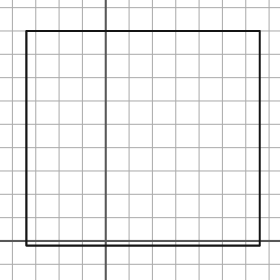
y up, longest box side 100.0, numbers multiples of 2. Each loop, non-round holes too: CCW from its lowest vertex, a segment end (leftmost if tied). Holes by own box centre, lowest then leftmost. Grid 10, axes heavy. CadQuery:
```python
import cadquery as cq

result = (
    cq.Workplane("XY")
    .moveTo(-34.0, -2.0)
    .lineTo(66.0, -2.0)
    .lineTo(66.0, 90.0)
    .lineTo(-34.0, 90.0)
    .close()
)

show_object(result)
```